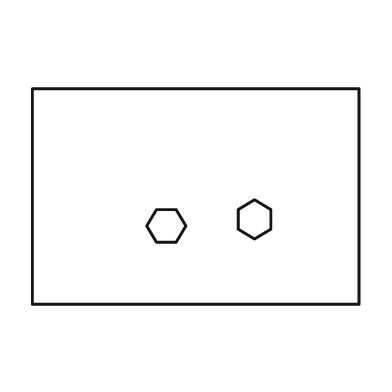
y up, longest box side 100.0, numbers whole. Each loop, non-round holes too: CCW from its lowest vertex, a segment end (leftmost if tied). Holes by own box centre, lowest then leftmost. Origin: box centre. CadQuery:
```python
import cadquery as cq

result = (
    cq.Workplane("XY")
    .moveTo(-50.0, -33.0)
    .lineTo(50.0, -33.0)
    .lineTo(50.0, 33.0)
    .lineTo(-50.0, 33.0)
    .close()
    .moveTo(-12.0, -14.0)
    .lineTo(-6.0, -14.0)
    .lineTo(-3.0, -9.0)
    .lineTo(-6.0, -4.0)
    .lineTo(-12.0, -4.0)
    .lineTo(-15.0, -9.0)
    .close()
    .moveTo(18.0, -13.0)
    .lineTo(23.0, -10.0)
    .lineTo(23.0, -4.0)
    .lineTo(18.0, -1.0)
    .lineTo(13.0, -4.0)
    .lineTo(13.0, -10.0)
    .close()
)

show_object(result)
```